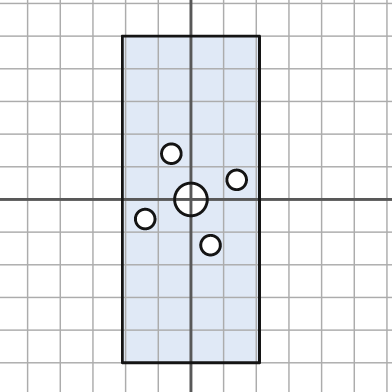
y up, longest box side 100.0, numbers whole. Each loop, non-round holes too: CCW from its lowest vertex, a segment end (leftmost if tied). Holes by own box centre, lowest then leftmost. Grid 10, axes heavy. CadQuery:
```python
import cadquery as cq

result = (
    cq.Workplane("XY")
    .moveTo(-21.0, -50.0)
    .lineTo(21.0, -50.0)
    .lineTo(21.0, 50.0)
    .lineTo(-21.0, 50.0)
    .close()
    .moveTo(6.0, -14.0)
    .circle(3.0)
    .moveTo(-14.0, -6.0)
    .circle(3.0)
    .moveTo(0.0, 0.0)
    .circle(5.0)
    .moveTo(14.0, 6.0)
    .circle(3.0)
    .moveTo(-6.0, 14.0)
    .circle(3.0)
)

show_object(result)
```